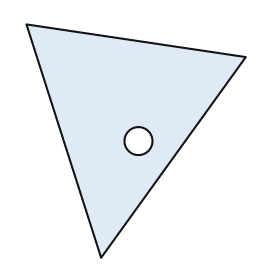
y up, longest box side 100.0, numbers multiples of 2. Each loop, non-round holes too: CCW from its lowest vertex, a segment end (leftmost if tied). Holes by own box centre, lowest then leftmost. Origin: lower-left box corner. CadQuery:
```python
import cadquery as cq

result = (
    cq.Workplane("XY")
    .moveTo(32.0, 0.0)
    .lineTo(94.0, 86.0)
    .lineTo(0.0, 100.0)
    .close()
    .moveTo(48.0, 50.0)
    .circle(6.0)
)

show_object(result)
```